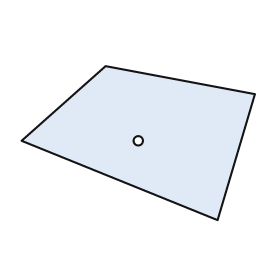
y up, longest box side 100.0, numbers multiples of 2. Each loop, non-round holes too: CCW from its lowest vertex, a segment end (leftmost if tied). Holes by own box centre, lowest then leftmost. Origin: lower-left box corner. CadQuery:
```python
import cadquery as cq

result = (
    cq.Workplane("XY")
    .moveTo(84.0, 0.0)
    .lineTo(100.0, 54.0)
    .lineTo(36.0, 66.0)
    .lineTo(0.0, 34.0)
    .close()
    .moveTo(50.0, 34.0)
    .circle(2.0)
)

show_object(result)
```